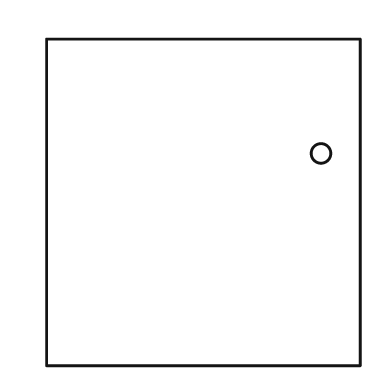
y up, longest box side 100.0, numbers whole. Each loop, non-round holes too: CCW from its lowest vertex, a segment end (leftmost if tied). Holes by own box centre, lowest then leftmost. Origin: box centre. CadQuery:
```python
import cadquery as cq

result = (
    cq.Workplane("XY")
    .moveTo(-48.0, -50.0)
    .lineTo(48.0, -50.0)
    .lineTo(48.0, 50.0)
    .lineTo(-48.0, 50.0)
    .close()
    .moveTo(36.0, 15.0)
    .circle(3.0)
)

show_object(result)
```